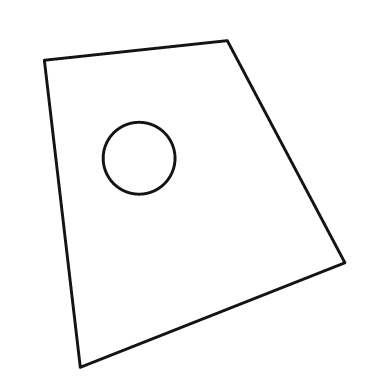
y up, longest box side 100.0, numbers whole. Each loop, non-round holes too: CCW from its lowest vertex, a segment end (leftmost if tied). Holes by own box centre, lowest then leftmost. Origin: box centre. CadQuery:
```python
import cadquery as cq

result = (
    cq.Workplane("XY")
    .moveTo(-35.0, -50.0)
    .lineTo(46.0, -18.0)
    .lineTo(10.0, 50.0)
    .lineTo(-46.0, 44.0)
    .close()
    .moveTo(-17.0, 14.0)
    .circle(11.0)
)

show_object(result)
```